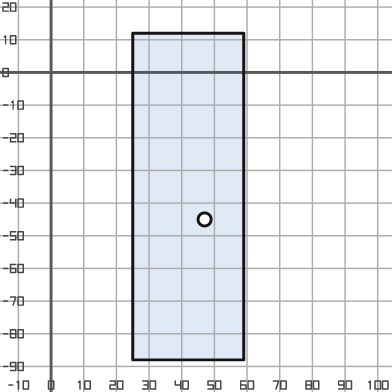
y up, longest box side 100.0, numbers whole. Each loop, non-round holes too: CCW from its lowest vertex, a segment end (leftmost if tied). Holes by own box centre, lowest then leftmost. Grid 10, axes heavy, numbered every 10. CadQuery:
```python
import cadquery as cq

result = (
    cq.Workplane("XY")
    .moveTo(25.0, -88.0)
    .lineTo(59.0, -88.0)
    .lineTo(59.0, 12.0)
    .lineTo(25.0, 12.0)
    .close()
    .moveTo(47.0, -45.0)
    .circle(2.0)
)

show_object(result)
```